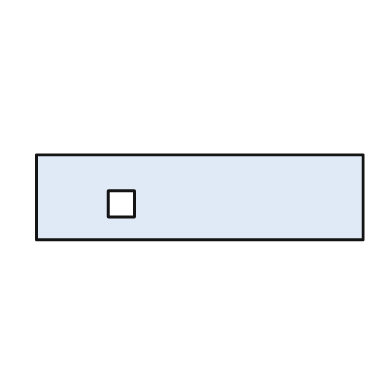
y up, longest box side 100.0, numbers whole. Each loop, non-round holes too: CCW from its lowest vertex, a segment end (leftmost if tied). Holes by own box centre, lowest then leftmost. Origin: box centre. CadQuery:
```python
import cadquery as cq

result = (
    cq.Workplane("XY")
    .moveTo(-50.0, -13.0)
    .lineTo(50.0, -13.0)
    .lineTo(50.0, 13.0)
    .lineTo(-50.0, 13.0)
    .close()
    .moveTo(-28.0, -6.0)
    .lineTo(-20.0, -6.0)
    .lineTo(-20.0, 2.0)
    .lineTo(-28.0, 2.0)
    .close()
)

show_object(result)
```